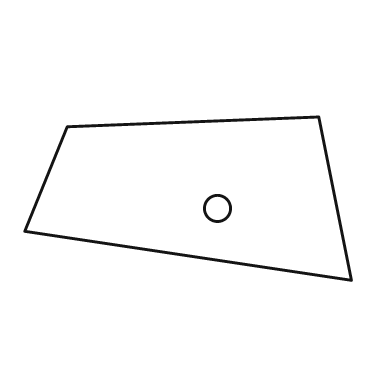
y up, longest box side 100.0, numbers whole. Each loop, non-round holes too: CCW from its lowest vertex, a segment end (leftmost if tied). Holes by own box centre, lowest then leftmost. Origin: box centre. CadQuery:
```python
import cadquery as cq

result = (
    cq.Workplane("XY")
    .moveTo(50.0, -25.0)
    .lineTo(40.0, 25.0)
    .lineTo(-37.0, 22.0)
    .lineTo(-50.0, -10.0)
    .close()
    .moveTo(9.0, -3.0)
    .circle(4.0)
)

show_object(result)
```